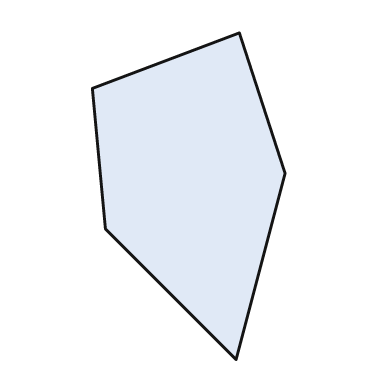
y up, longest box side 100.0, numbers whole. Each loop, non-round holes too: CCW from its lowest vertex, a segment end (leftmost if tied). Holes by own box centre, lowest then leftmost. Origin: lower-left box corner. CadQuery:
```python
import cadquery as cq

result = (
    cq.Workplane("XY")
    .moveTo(44.0, 0.0)
    .lineTo(59.0, 57.0)
    .lineTo(45.0, 100.0)
    .lineTo(0.0, 83.0)
    .lineTo(4.0, 40.0)
    .close()
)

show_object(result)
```